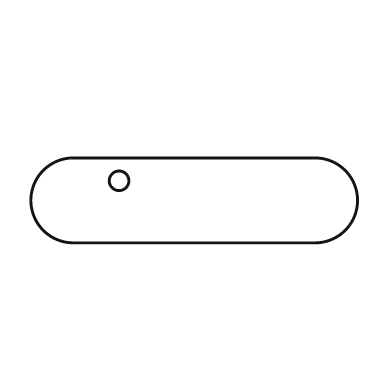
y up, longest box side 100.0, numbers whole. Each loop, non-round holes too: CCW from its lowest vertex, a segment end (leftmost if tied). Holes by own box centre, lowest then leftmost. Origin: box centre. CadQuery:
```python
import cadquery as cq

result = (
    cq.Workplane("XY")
    .moveTo(-37.0, -13.0)
    .lineTo(37.0, -13.0)
    .threePointArc((50.0, 0.0), (37.0, 13.0))
    .lineTo(-37.0, 13.0)
    .threePointArc((-50.0, 0.0), (-37.0, -13.0))
    .close()
    .moveTo(-23.0, 6.0)
    .circle(3.0)
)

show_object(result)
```